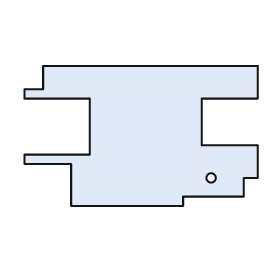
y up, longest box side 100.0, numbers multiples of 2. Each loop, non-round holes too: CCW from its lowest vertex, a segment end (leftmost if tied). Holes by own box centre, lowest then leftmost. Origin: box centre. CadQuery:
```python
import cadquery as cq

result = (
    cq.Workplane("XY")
    .moveTo(-30.0, -30.0)
    .lineTo(18.0, -30.0)
    .lineTo(18.0, -26.0)
    .lineTo(44.0, -26.0)
    .lineTo(44.0, -18.0)
    .lineTo(50.0, -18.0)
    .lineTo(50.0, -4.0)
    .lineTo(26.0, -4.0)
    .lineTo(26.0, 16.0)
    .lineTo(50.0, 16.0)
    .lineTo(50.0, 30.0)
    .lineTo(-42.0, 30.0)
    .lineTo(-42.0, 20.0)
    .lineTo(-50.0, 20.0)
    .lineTo(-50.0, 16.0)
    .lineTo(-22.0, 16.0)
    .lineTo(-22.0, -8.0)
    .lineTo(-50.0, -8.0)
    .lineTo(-50.0, -12.0)
    .lineTo(-30.0, -12.0)
    .close()
    .moveTo(30.0, -18.0)
    .circle(2.0)
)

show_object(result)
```